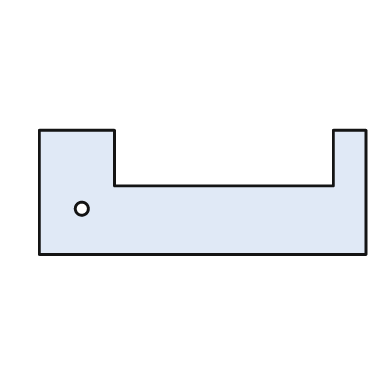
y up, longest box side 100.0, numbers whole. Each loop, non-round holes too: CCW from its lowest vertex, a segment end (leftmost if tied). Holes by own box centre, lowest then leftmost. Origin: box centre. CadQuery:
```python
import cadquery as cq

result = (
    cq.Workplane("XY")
    .moveTo(-50.0, -19.0)
    .lineTo(50.0, -19.0)
    .lineTo(50.0, 19.0)
    .lineTo(40.0, 19.0)
    .lineTo(40.0, 2.0)
    .lineTo(-27.0, 2.0)
    .lineTo(-27.0, 19.0)
    .lineTo(-50.0, 19.0)
    .close()
    .moveTo(-37.0, -5.0)
    .circle(2.0)
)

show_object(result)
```